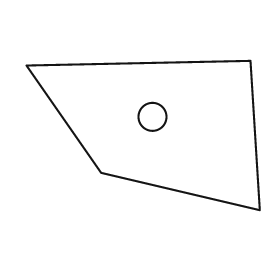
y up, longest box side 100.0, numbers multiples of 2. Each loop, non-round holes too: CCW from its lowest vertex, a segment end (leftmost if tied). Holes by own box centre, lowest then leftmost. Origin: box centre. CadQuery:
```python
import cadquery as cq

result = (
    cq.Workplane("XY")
    .moveTo(50.0, -32.0)
    .lineTo(46.0, 32.0)
    .lineTo(-50.0, 30.0)
    .lineTo(-18.0, -16.0)
    .close()
    .moveTo(4.0, 8.0)
    .circle(6.0)
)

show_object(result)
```